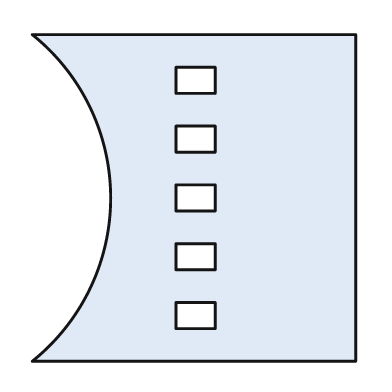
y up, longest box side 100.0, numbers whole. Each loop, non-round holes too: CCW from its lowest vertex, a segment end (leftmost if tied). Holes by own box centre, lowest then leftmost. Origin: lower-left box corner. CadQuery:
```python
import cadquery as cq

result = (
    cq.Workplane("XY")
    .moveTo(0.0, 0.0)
    .lineTo(99.0, 0.0)
    .lineTo(99.0, 100.0)
    .lineTo(0.0, 100.0)
    .threePointArc((24.0, 50.0), (0.0, 0.0))
    .close()
    .moveTo(44.0, 10.0)
    .lineTo(56.0, 10.0)
    .lineTo(56.0, 18.0)
    .lineTo(44.0, 18.0)
    .close()
    .moveTo(44.0, 28.0)
    .lineTo(56.0, 28.0)
    .lineTo(56.0, 36.0)
    .lineTo(44.0, 36.0)
    .close()
    .moveTo(44.0, 46.0)
    .lineTo(56.0, 46.0)
    .lineTo(56.0, 54.0)
    .lineTo(44.0, 54.0)
    .close()
    .moveTo(44.0, 64.0)
    .lineTo(56.0, 64.0)
    .lineTo(56.0, 72.0)
    .lineTo(44.0, 72.0)
    .close()
    .moveTo(44.0, 82.0)
    .lineTo(56.0, 82.0)
    .lineTo(56.0, 90.0)
    .lineTo(44.0, 90.0)
    .close()
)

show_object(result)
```